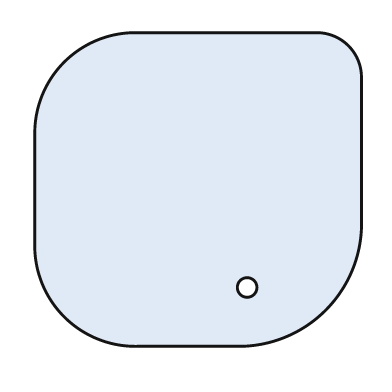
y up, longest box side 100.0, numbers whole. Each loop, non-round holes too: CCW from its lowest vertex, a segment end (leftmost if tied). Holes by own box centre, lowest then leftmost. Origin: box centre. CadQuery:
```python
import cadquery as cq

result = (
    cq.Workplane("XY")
    .moveTo(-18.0, -48.0)
    .lineTo(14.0, -48.0)
    .threePointArc((39.0, -37.0), (50.0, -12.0))
    .lineTo(50.0, 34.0)
    .threePointArc((46.0, 44.0), (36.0, 48.0))
    .lineTo(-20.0, 48.0)
    .threePointArc((-41.0, 39.0), (-50.0, 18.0))
    .lineTo(-50.0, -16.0)
    .threePointArc((-41.0, -39.0), (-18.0, -48.0))
    .close()
    .moveTo(15.0, -30.0)
    .circle(3.0)
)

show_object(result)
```